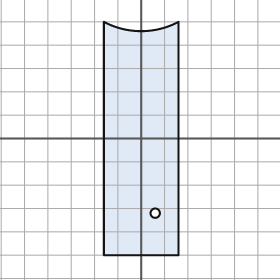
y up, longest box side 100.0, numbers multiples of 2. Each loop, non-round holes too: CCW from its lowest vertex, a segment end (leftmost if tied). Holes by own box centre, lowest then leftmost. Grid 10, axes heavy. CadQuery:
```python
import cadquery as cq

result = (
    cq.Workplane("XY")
    .moveTo(-16.0, -50.0)
    .lineTo(16.0, -50.0)
    .lineTo(16.0, 50.0)
    .threePointArc((0.0, 46.0), (-16.0, 50.0))
    .close()
    .moveTo(6.0, -32.0)
    .circle(2.0)
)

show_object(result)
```